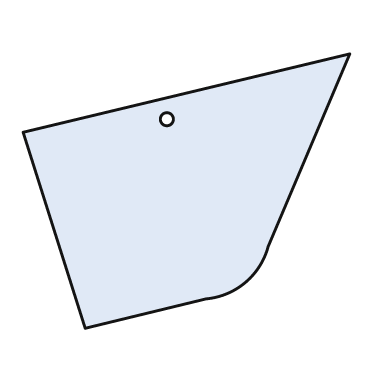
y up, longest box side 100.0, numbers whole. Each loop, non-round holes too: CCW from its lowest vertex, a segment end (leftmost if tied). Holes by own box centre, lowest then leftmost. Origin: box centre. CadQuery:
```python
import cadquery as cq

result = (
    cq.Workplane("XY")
    .moveTo(-31.0, -42.0)
    .lineTo(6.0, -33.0)
    .threePointArc((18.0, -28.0), (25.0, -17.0))
    .lineTo(50.0, 42.0)
    .lineTo(-50.0, 18.0)
    .close()
    .moveTo(-6.0, 22.0)
    .circle(2.0)
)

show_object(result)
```